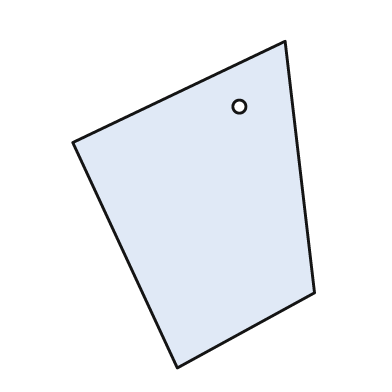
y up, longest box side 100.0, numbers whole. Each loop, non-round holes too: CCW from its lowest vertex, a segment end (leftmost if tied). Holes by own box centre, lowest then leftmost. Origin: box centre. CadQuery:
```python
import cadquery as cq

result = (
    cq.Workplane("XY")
    .moveTo(-5.0, -50.0)
    .lineTo(37.0, -27.0)
    .lineTo(28.0, 50.0)
    .lineTo(-37.0, 19.0)
    .close()
    .moveTo(14.0, 30.0)
    .circle(2.0)
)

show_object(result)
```